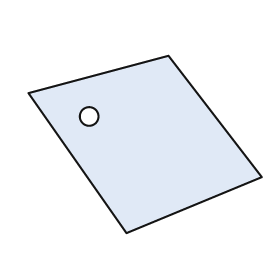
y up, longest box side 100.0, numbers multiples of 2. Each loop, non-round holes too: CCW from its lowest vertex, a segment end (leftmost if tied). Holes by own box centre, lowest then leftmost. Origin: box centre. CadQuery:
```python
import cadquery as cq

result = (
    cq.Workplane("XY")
    .moveTo(-8.0, -38.0)
    .lineTo(50.0, -14.0)
    .lineTo(10.0, 38.0)
    .lineTo(-50.0, 22.0)
    .close()
    .moveTo(-24.0, 12.0)
    .circle(4.0)
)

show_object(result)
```